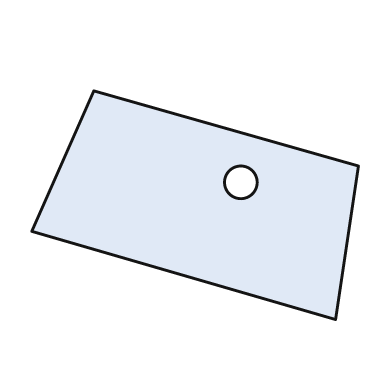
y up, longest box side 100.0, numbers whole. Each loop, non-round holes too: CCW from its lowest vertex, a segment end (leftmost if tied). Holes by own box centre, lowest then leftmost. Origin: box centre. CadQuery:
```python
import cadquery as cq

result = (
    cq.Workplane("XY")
    .moveTo(43.0, -35.0)
    .lineTo(50.0, 12.0)
    .lineTo(-31.0, 35.0)
    .lineTo(-50.0, -8.0)
    .close()
    .moveTo(14.0, 7.0)
    .circle(5.0)
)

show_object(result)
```